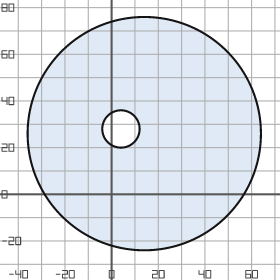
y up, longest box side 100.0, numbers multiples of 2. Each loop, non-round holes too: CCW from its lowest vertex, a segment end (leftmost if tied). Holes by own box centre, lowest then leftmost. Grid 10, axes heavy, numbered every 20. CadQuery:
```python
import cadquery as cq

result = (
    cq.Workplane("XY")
    .moveTo(14.0, 26.0)
    .circle(50.0)
    .moveTo(4.0, 28.0)
    .circle(8.0)
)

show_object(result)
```